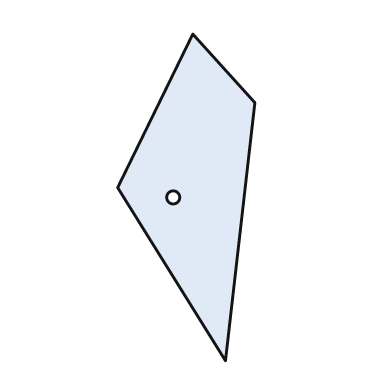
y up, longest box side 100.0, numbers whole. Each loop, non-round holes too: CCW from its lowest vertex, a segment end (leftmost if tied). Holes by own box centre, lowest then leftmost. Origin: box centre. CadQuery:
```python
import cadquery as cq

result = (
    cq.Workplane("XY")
    .moveTo(12.0, -50.0)
    .lineTo(21.0, 29.0)
    .lineTo(2.0, 50.0)
    .lineTo(-21.0, 3.0)
    .close()
    .moveTo(-4.0, 0.0)
    .circle(2.0)
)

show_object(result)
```